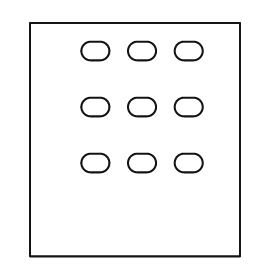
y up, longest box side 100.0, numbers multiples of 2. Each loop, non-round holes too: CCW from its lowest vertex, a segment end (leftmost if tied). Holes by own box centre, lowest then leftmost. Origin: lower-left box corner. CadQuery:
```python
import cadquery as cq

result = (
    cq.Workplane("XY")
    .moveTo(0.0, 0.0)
    .lineTo(90.0, 0.0)
    .lineTo(90.0, 100.0)
    .lineTo(0.0, 100.0)
    .close()
    .moveTo(26.0, 36.0)
    .lineTo(30.0, 36.0)
    .threePointArc((34.0, 40.0), (30.0, 44.0))
    .lineTo(26.0, 44.0)
    .threePointArc((22.0, 40.0), (26.0, 36.0))
    .close()
    .moveTo(46.0, 36.0)
    .lineTo(50.0, 36.0)
    .threePointArc((54.0, 40.0), (50.0, 44.0))
    .lineTo(46.0, 44.0)
    .threePointArc((42.0, 40.0), (46.0, 36.0))
    .close()
    .moveTo(66.0, 36.0)
    .lineTo(70.0, 36.0)
    .threePointArc((74.0, 40.0), (70.0, 44.0))
    .lineTo(66.0, 44.0)
    .threePointArc((62.0, 40.0), (66.0, 36.0))
    .close()
    .moveTo(26.0, 60.0)
    .lineTo(30.0, 60.0)
    .threePointArc((34.0, 64.0), (30.0, 68.0))
    .lineTo(26.0, 68.0)
    .threePointArc((22.0, 64.0), (26.0, 60.0))
    .close()
    .moveTo(46.0, 60.0)
    .lineTo(50.0, 60.0)
    .threePointArc((54.0, 64.0), (50.0, 68.0))
    .lineTo(46.0, 68.0)
    .threePointArc((42.0, 64.0), (46.0, 60.0))
    .close()
    .moveTo(66.0, 60.0)
    .lineTo(70.0, 60.0)
    .threePointArc((74.0, 64.0), (70.0, 68.0))
    .lineTo(66.0, 68.0)
    .threePointArc((62.0, 64.0), (66.0, 60.0))
    .close()
    .moveTo(26.0, 84.0)
    .lineTo(30.0, 84.0)
    .threePointArc((34.0, 88.0), (30.0, 92.0))
    .lineTo(26.0, 92.0)
    .threePointArc((22.0, 88.0), (26.0, 84.0))
    .close()
    .moveTo(46.0, 84.0)
    .lineTo(50.0, 84.0)
    .threePointArc((54.0, 88.0), (50.0, 92.0))
    .lineTo(46.0, 92.0)
    .threePointArc((42.0, 88.0), (46.0, 84.0))
    .close()
    .moveTo(66.0, 84.0)
    .lineTo(70.0, 84.0)
    .threePointArc((74.0, 88.0), (70.0, 92.0))
    .lineTo(66.0, 92.0)
    .threePointArc((62.0, 88.0), (66.0, 84.0))
    .close()
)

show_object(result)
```